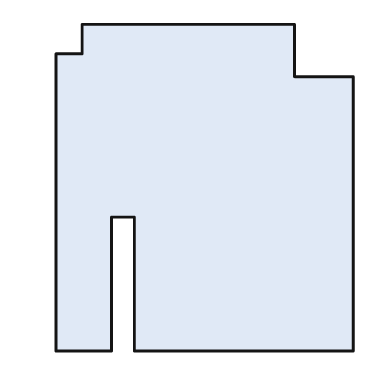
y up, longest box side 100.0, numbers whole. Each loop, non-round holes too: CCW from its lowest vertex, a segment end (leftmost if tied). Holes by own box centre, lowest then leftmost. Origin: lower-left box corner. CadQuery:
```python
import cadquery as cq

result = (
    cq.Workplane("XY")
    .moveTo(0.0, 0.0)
    .lineTo(17.0, 0.0)
    .lineTo(17.0, 41.0)
    .lineTo(24.0, 41.0)
    .lineTo(24.0, 0.0)
    .lineTo(91.0, 0.0)
    .lineTo(91.0, 84.0)
    .lineTo(73.0, 84.0)
    .lineTo(73.0, 100.0)
    .lineTo(8.0, 100.0)
    .lineTo(8.0, 91.0)
    .lineTo(0.0, 91.0)
    .close()
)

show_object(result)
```